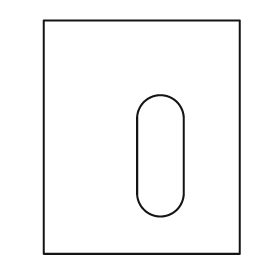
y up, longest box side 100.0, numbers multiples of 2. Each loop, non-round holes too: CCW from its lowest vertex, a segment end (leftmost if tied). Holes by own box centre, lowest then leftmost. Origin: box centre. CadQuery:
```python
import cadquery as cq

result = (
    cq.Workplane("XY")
    .moveTo(-42.0, -50.0)
    .lineTo(42.0, -50.0)
    .lineTo(42.0, 50.0)
    .lineTo(-42.0, 50.0)
    .close()
    .moveTo(-2.0, -24.0)
    .threePointArc((8.0, -34.0), (18.0, -24.0))
    .lineTo(18.0, 8.0)
    .threePointArc((8.0, 18.0), (-2.0, 8.0))
    .close()
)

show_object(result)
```